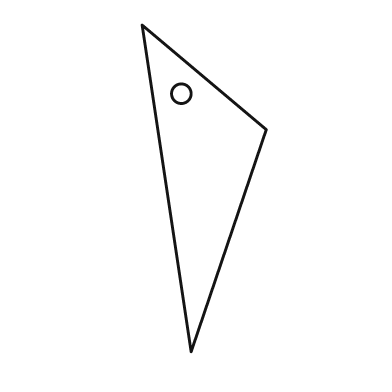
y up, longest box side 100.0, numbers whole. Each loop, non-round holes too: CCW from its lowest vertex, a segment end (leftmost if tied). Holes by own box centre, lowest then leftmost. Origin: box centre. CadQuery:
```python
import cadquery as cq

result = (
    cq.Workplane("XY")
    .moveTo(-4.0, -50.0)
    .lineTo(19.0, 18.0)
    .lineTo(-19.0, 50.0)
    .close()
    .moveTo(-7.0, 29.0)
    .circle(3.0)
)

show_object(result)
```